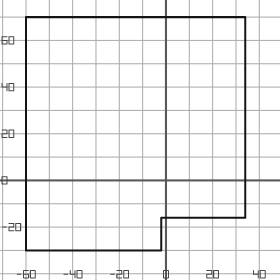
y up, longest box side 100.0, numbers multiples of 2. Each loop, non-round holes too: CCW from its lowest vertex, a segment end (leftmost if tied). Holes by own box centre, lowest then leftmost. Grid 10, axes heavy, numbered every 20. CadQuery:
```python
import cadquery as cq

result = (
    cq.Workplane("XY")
    .moveTo(-60.0, -30.0)
    .lineTo(-2.0, -30.0)
    .lineTo(-2.0, -16.0)
    .lineTo(34.0, -16.0)
    .lineTo(34.0, 70.0)
    .lineTo(-60.0, 70.0)
    .close()
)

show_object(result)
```